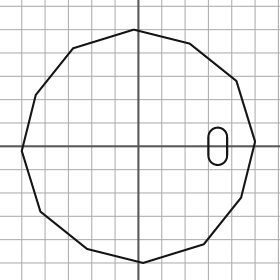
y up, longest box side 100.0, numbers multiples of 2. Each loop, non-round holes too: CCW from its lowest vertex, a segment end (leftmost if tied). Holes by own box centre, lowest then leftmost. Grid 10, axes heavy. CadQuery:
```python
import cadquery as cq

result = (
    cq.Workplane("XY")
    .moveTo(2.0, -50.0)
    .lineTo(28.0, -42.0)
    .lineTo(44.0, -22.0)
    .lineTo(50.0, 2.0)
    .lineTo(42.0, 28.0)
    .lineTo(22.0, 44.0)
    .lineTo(-2.0, 50.0)
    .lineTo(-28.0, 42.0)
    .lineTo(-44.0, 22.0)
    .lineTo(-50.0, -2.0)
    .lineTo(-42.0, -28.0)
    .lineTo(-22.0, -44.0)
    .close()
    .moveTo(30.0, -4.0)
    .threePointArc((34.0, -8.0), (38.0, -4.0))
    .lineTo(38.0, 4.0)
    .threePointArc((34.0, 8.0), (30.0, 4.0))
    .close()
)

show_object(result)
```